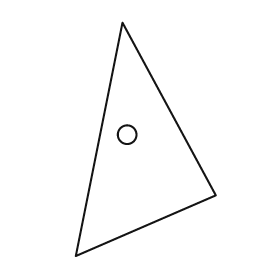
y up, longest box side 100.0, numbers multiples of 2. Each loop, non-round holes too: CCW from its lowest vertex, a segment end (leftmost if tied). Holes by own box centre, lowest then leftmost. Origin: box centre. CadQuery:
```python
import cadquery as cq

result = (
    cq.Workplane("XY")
    .moveTo(-30.0, -50.0)
    .lineTo(30.0, -24.0)
    .lineTo(-10.0, 50.0)
    .close()
    .moveTo(-8.0, 2.0)
    .circle(4.0)
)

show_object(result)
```